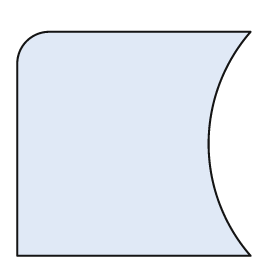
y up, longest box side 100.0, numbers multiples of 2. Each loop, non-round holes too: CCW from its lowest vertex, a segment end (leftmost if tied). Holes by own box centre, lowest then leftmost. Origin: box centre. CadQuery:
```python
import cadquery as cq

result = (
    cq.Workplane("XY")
    .moveTo(-50.0, -48.0)
    .lineTo(50.0, -48.0)
    .threePointArc((32.0, 0.0), (50.0, 48.0))
    .lineTo(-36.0, 48.0)
    .threePointArc((-46.0, 44.0), (-50.0, 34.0))
    .close()
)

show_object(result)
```